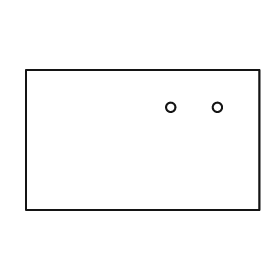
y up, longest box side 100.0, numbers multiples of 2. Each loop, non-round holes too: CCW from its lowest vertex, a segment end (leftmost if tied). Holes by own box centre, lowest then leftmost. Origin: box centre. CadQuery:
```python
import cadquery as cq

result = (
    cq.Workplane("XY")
    .moveTo(-50.0, -30.0)
    .lineTo(50.0, -30.0)
    .lineTo(50.0, 30.0)
    .lineTo(-50.0, 30.0)
    .close()
    .moveTo(12.0, 14.0)
    .circle(2.0)
    .moveTo(32.0, 14.0)
    .circle(2.0)
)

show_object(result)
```